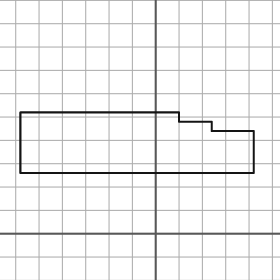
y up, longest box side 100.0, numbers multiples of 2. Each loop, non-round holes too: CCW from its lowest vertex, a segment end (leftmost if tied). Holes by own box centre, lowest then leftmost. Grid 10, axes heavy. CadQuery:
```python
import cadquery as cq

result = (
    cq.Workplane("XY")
    .moveTo(-58.0, 26.0)
    .lineTo(42.0, 26.0)
    .lineTo(42.0, 44.0)
    .lineTo(24.0, 44.0)
    .lineTo(24.0, 48.0)
    .lineTo(10.0, 48.0)
    .lineTo(10.0, 52.0)
    .lineTo(-58.0, 52.0)
    .close()
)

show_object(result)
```